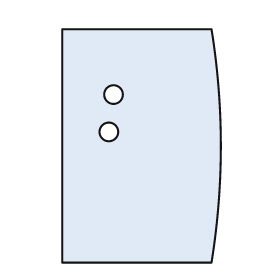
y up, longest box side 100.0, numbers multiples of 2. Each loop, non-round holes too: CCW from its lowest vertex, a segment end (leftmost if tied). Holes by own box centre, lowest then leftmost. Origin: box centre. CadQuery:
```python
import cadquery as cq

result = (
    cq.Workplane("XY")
    .moveTo(-34.0, -50.0)
    .lineTo(30.0, -50.0)
    .threePointArc((34.0, 0.0), (30.0, 50.0))
    .lineTo(-34.0, 50.0)
    .close()
    .moveTo(-14.0, 6.0)
    .circle(4.0)
    .moveTo(-12.0, 22.0)
    .circle(4.0)
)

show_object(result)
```